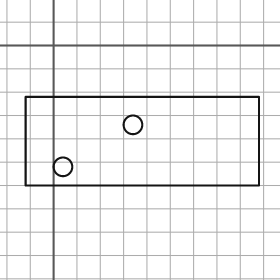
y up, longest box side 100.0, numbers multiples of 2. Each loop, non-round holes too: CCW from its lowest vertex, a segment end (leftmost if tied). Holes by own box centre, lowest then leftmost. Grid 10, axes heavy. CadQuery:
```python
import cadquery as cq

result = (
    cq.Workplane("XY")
    .moveTo(-12.0, -60.0)
    .lineTo(88.0, -60.0)
    .lineTo(88.0, -22.0)
    .lineTo(-12.0, -22.0)
    .close()
    .moveTo(4.0, -52.0)
    .circle(4.0)
    .moveTo(34.0, -34.0)
    .circle(4.0)
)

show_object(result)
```